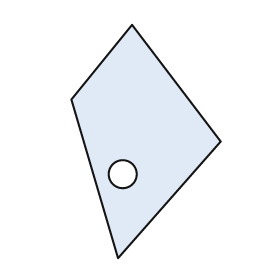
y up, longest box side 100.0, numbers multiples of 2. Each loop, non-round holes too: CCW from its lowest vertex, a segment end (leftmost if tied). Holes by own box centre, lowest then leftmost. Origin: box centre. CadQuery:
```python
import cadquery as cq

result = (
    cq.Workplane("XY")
    .moveTo(-12.0, -50.0)
    .lineTo(32.0, 0.0)
    .lineTo(-6.0, 50.0)
    .lineTo(-32.0, 18.0)
    .close()
    .moveTo(-10.0, -14.0)
    .circle(6.0)
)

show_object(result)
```